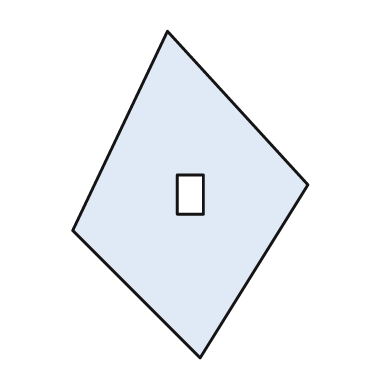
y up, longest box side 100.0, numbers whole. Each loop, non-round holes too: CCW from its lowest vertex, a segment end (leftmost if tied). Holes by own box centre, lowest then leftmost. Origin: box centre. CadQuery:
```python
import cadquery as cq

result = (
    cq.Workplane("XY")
    .moveTo(3.0, -50.0)
    .lineTo(36.0, 3.0)
    .lineTo(-7.0, 50.0)
    .lineTo(-36.0, -11.0)
    .close()
    .moveTo(-4.0, -6.0)
    .lineTo(4.0, -6.0)
    .lineTo(4.0, 6.0)
    .lineTo(-4.0, 6.0)
    .close()
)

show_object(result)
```